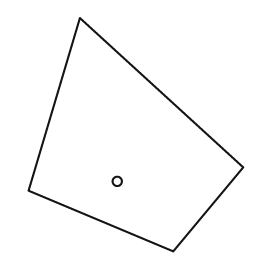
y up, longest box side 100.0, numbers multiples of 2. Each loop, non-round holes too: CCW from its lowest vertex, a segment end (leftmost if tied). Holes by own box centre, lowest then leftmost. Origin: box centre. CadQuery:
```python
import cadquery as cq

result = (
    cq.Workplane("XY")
    .moveTo(16.0, -50.0)
    .lineTo(46.0, -14.0)
    .lineTo(-24.0, 50.0)
    .lineTo(-46.0, -24.0)
    .close()
    .moveTo(-8.0, -20.0)
    .circle(2.0)
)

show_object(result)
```